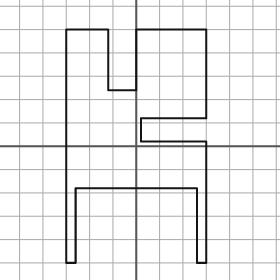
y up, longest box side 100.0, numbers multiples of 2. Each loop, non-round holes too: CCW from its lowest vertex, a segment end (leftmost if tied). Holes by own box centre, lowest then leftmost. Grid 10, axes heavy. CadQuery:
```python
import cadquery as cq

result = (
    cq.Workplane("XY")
    .moveTo(-30.0, -50.0)
    .lineTo(-26.0, -50.0)
    .lineTo(-26.0, -18.0)
    .lineTo(26.0, -18.0)
    .lineTo(26.0, -50.0)
    .lineTo(30.0, -50.0)
    .lineTo(30.0, 2.0)
    .lineTo(2.0, 2.0)
    .lineTo(2.0, 12.0)
    .lineTo(30.0, 12.0)
    .lineTo(30.0, 50.0)
    .lineTo(0.0, 50.0)
    .lineTo(0.0, 24.0)
    .lineTo(-12.0, 24.0)
    .lineTo(-12.0, 50.0)
    .lineTo(-30.0, 50.0)
    .close()
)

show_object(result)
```